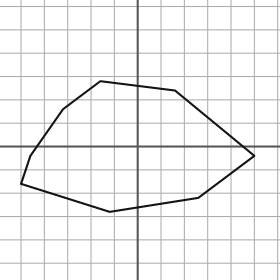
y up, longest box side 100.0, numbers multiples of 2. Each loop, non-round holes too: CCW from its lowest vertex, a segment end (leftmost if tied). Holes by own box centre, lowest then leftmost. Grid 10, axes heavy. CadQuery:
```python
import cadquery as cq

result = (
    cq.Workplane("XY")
    .moveTo(-12.0, -28.0)
    .lineTo(26.0, -22.0)
    .lineTo(50.0, -4.0)
    .lineTo(16.0, 24.0)
    .lineTo(-16.0, 28.0)
    .lineTo(-32.0, 16.0)
    .lineTo(-46.0, -4.0)
    .lineTo(-50.0, -16.0)
    .close()
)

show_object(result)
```